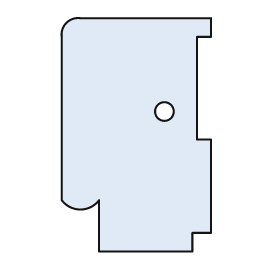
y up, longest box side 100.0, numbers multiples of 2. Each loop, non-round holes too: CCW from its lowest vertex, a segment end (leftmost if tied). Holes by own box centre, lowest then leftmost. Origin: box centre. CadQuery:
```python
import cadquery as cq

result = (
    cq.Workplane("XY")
    .moveTo(-16.0, -50.0)
    .lineTo(24.0, -50.0)
    .lineTo(24.0, -42.0)
    .lineTo(32.0, -42.0)
    .lineTo(32.0, -2.0)
    .lineTo(26.0, -2.0)
    .lineTo(26.0, 42.0)
    .lineTo(32.0, 42.0)
    .lineTo(32.0, 50.0)
    .lineTo(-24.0, 50.0)
    .threePointArc((-30.0, 48.0), (-32.0, 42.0))
    .lineTo(-32.0, -28.0)
    .threePointArc((-24.0, -32.0), (-16.0, -28.0))
    .close()
    .moveTo(12.0, 10.0)
    .circle(4.0)
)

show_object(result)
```